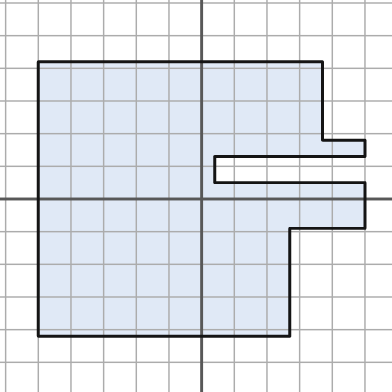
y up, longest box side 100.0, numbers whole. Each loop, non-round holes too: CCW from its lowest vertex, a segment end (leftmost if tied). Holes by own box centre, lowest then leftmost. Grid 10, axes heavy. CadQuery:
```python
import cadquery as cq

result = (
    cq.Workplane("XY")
    .moveTo(-50.0, -42.0)
    .lineTo(27.0, -42.0)
    .lineTo(27.0, -9.0)
    .lineTo(50.0, -9.0)
    .lineTo(50.0, 5.0)
    .lineTo(4.0, 5.0)
    .lineTo(4.0, 13.0)
    .lineTo(50.0, 13.0)
    .lineTo(50.0, 18.0)
    .lineTo(37.0, 18.0)
    .lineTo(37.0, 42.0)
    .lineTo(-50.0, 42.0)
    .close()
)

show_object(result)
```